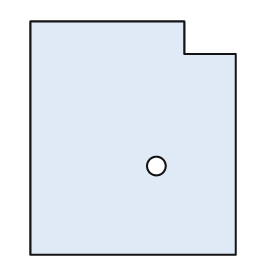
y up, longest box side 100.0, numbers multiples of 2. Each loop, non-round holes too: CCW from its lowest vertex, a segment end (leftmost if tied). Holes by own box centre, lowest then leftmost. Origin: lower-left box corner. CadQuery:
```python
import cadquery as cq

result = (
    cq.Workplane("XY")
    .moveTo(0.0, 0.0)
    .lineTo(88.0, 0.0)
    .lineTo(88.0, 86.0)
    .lineTo(66.0, 86.0)
    .lineTo(66.0, 100.0)
    .lineTo(0.0, 100.0)
    .close()
    .moveTo(54.0, 38.0)
    .circle(4.0)
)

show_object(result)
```